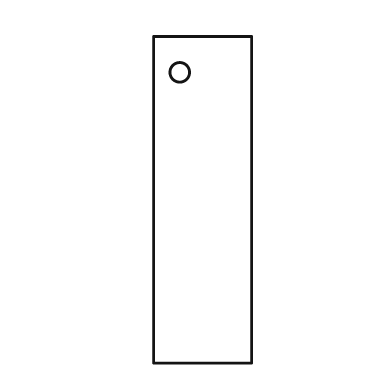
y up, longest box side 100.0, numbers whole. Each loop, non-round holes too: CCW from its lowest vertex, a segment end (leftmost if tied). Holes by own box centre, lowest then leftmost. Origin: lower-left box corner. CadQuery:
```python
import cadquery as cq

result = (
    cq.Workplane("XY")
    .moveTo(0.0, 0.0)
    .lineTo(30.0, 0.0)
    .lineTo(30.0, 100.0)
    .lineTo(0.0, 100.0)
    .close()
    .moveTo(8.0, 89.0)
    .circle(3.0)
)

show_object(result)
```